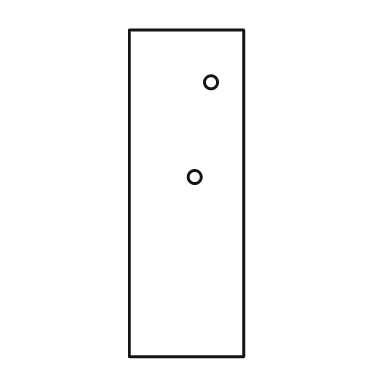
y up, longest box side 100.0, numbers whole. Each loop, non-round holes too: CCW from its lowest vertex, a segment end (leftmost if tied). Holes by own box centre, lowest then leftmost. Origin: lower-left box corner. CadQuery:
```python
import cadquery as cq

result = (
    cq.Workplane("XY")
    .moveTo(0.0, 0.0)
    .lineTo(35.0, 0.0)
    .lineTo(35.0, 100.0)
    .lineTo(0.0, 100.0)
    .close()
    .moveTo(20.0, 55.0)
    .circle(2.0)
    .moveTo(25.0, 84.0)
    .circle(2.0)
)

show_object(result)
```